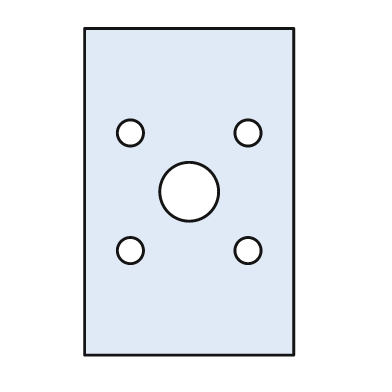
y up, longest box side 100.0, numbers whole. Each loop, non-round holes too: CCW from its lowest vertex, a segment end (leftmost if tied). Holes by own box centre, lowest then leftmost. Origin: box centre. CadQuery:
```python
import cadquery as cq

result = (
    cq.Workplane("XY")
    .moveTo(-32.0, -50.0)
    .lineTo(32.0, -50.0)
    .lineTo(32.0, 50.0)
    .lineTo(-32.0, 50.0)
    .close()
    .moveTo(-18.0, -18.0)
    .circle(4.0)
    .moveTo(18.0, -18.0)
    .circle(4.0)
    .moveTo(0.0, 0.0)
    .circle(9.0)
    .moveTo(-18.0, 18.0)
    .circle(4.0)
    .moveTo(18.0, 18.0)
    .circle(4.0)
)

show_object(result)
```